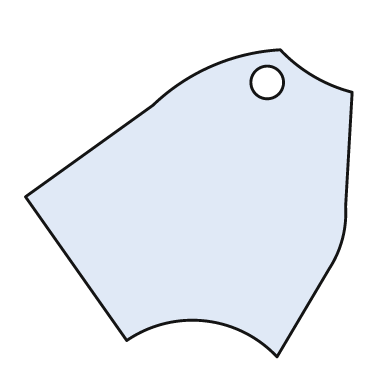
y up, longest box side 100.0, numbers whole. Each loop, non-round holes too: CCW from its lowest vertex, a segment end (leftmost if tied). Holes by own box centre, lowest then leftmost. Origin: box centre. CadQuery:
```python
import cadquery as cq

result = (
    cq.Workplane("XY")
    .moveTo(27.0, -47.0)
    .lineTo(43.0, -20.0)
    .threePointArc((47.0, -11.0), (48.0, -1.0))
    .lineTo(50.0, 34.0)
    .threePointArc((38.0, 39.0), (28.0, 47.0))
    .threePointArc((7.0, 42.0), (-11.0, 30.0))
    .lineTo(-50.0, 2.0)
    .lineTo(-19.0, -42.0)
    .threePointArc((5.0, -36.0), (27.0, -47.0))
    .close()
    .moveTo(24.0, 37.0)
    .circle(5.0)
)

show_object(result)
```